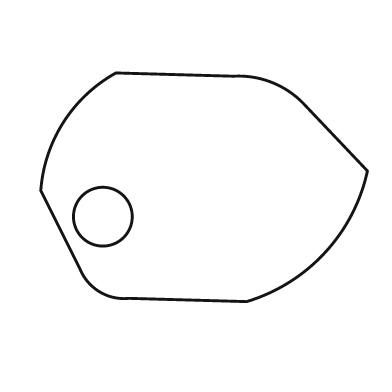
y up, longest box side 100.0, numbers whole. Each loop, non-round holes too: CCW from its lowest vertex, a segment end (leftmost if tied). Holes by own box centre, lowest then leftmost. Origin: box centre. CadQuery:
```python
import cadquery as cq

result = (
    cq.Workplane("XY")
    .moveTo(13.0, -35.0)
    .threePointArc((37.0, -20.0), (50.0, 5.0))
    .lineTo(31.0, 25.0)
    .threePointArc((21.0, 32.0), (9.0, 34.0))
    .lineTo(-27.0, 35.0)
    .threePointArc((-43.0, 20.0), (-50.0, -1.0))
    .lineTo(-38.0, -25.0)
    .threePointArc((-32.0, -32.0), (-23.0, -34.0))
    .close()
    .moveTo(-31.0, -9.0)
    .circle(9.0)
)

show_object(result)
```